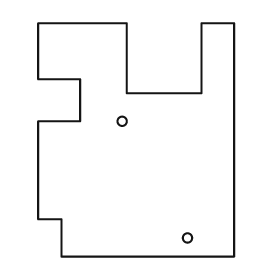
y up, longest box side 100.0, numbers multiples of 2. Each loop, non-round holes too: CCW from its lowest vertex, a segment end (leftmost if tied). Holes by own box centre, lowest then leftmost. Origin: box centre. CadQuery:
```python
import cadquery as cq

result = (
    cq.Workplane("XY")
    .moveTo(-32.0, -50.0)
    .lineTo(42.0, -50.0)
    .lineTo(42.0, 50.0)
    .lineTo(28.0, 50.0)
    .lineTo(28.0, 20.0)
    .lineTo(-4.0, 20.0)
    .lineTo(-4.0, 50.0)
    .lineTo(-42.0, 50.0)
    .lineTo(-42.0, 26.0)
    .lineTo(-24.0, 26.0)
    .lineTo(-24.0, 8.0)
    .lineTo(-42.0, 8.0)
    .lineTo(-42.0, -34.0)
    .lineTo(-32.0, -34.0)
    .close()
    .moveTo(22.0, -42.0)
    .circle(2.0)
    .moveTo(-6.0, 8.0)
    .circle(2.0)
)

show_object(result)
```